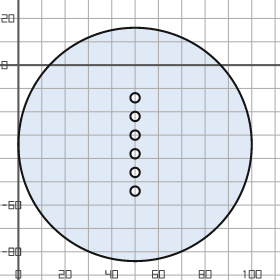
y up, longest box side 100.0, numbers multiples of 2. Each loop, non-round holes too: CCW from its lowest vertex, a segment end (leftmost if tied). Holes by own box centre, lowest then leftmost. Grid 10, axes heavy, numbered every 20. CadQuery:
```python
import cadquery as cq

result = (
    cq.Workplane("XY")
    .moveTo(50.0, -34.0)
    .circle(50.0)
    .moveTo(50.0, -54.0)
    .circle(2.0)
    .moveTo(50.0, -46.0)
    .circle(2.0)
    .moveTo(50.0, -38.0)
    .circle(2.0)
    .moveTo(50.0, -30.0)
    .circle(2.0)
    .moveTo(50.0, -22.0)
    .circle(2.0)
    .moveTo(50.0, -14.0)
    .circle(2.0)
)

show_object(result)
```